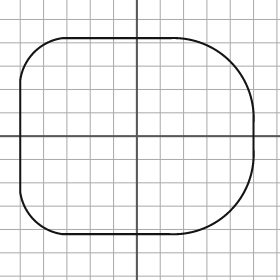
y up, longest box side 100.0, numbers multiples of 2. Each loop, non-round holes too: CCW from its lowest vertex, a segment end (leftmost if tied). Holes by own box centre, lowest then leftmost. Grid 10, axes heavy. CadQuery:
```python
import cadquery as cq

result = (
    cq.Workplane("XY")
    .moveTo(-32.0, -42.0)
    .lineTo(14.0, -42.0)
    .threePointArc((40.0, -32.0), (50.0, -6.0))
    .lineTo(50.0, 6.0)
    .threePointArc((40.0, 32.0), (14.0, 42.0))
    .lineTo(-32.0, 42.0)
    .threePointArc((-44.0, 36.0), (-50.0, 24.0))
    .lineTo(-50.0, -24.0)
    .threePointArc((-44.0, -36.0), (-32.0, -42.0))
    .close()
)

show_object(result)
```